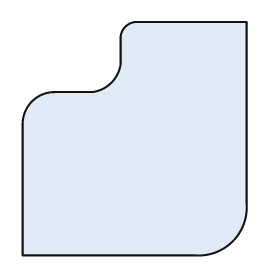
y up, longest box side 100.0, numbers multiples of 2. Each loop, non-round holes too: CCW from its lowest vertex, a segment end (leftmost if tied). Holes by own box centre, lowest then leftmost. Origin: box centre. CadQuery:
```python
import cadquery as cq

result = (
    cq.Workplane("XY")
    .moveTo(-48.0, -50.0)
    .lineTo(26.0, -50.0)
    .threePointArc((42.0, -44.0), (48.0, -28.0))
    .lineTo(48.0, 50.0)
    .lineTo(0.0, 50.0)
    .threePointArc((-4.0, 48.0), (-6.0, 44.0))
    .lineTo(-6.0, 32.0)
    .threePointArc((-10.0, 24.0), (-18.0, 20.0))
    .lineTo(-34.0, 20.0)
    .threePointArc((-44.0, 16.0), (-48.0, 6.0))
    .close()
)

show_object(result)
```